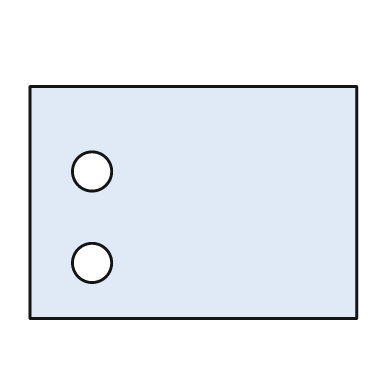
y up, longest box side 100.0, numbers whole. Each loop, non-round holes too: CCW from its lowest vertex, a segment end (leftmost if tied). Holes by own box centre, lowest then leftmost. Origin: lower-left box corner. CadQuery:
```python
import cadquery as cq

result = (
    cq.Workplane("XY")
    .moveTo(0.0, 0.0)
    .lineTo(100.0, 0.0)
    .lineTo(100.0, 71.0)
    .lineTo(0.0, 71.0)
    .close()
    .moveTo(19.0, 17.0)
    .circle(6.0)
    .moveTo(19.0, 45.0)
    .circle(6.0)
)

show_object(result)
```